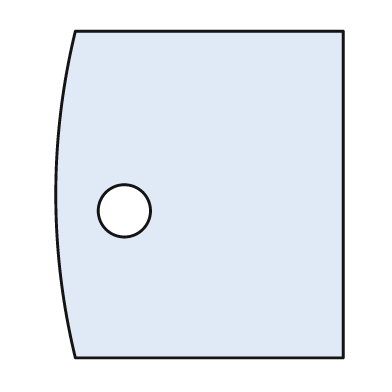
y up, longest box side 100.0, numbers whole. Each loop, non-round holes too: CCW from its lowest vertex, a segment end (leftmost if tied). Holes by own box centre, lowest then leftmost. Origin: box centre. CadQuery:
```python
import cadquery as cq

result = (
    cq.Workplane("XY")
    .moveTo(-38.0, -50.0)
    .lineTo(44.0, -50.0)
    .lineTo(44.0, 50.0)
    .lineTo(-38.0, 50.0)
    .threePointArc((-44.0, 0.0), (-38.0, -50.0))
    .close()
    .moveTo(-23.0, -5.0)
    .circle(8.0)
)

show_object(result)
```